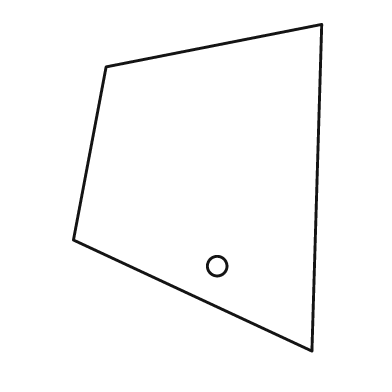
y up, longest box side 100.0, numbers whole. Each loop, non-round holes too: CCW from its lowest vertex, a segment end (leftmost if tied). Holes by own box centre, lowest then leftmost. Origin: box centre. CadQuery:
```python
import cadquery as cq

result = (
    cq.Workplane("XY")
    .moveTo(35.0, -50.0)
    .lineTo(38.0, 50.0)
    .lineTo(-28.0, 37.0)
    .lineTo(-38.0, -16.0)
    .close()
    .moveTo(6.0, -24.0)
    .circle(3.0)
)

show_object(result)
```